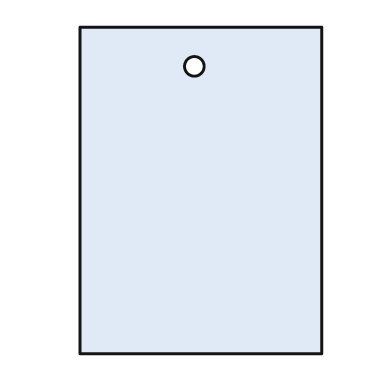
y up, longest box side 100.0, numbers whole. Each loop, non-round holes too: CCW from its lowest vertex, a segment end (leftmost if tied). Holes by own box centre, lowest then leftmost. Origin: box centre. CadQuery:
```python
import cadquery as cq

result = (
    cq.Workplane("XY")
    .moveTo(-37.0, -50.0)
    .lineTo(37.0, -50.0)
    .lineTo(37.0, 50.0)
    .lineTo(-37.0, 50.0)
    .close()
    .moveTo(-2.0, 38.0)
    .circle(3.0)
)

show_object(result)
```